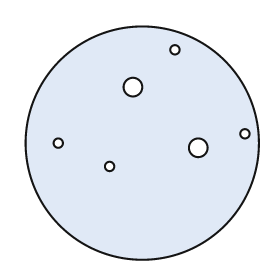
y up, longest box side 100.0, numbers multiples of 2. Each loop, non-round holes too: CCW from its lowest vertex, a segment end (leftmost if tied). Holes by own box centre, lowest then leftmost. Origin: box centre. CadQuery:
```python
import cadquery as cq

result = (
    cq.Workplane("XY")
    .moveTo(0.0, 0.0)
    .circle(50.0)
    .moveTo(-14.0, -10.0)
    .circle(2.0)
    .moveTo(24.0, -2.0)
    .circle(4.0)
    .moveTo(-36.0, 0.0)
    .circle(2.0)
    .moveTo(44.0, 4.0)
    .circle(2.0)
    .moveTo(-4.0, 24.0)
    .circle(4.0)
    .moveTo(14.0, 40.0)
    .circle(2.0)
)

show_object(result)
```